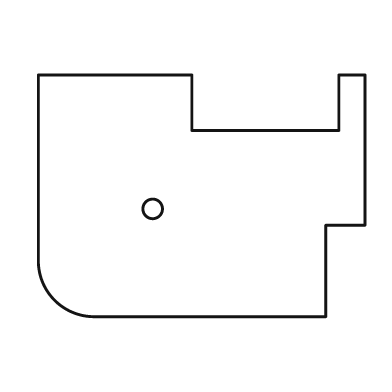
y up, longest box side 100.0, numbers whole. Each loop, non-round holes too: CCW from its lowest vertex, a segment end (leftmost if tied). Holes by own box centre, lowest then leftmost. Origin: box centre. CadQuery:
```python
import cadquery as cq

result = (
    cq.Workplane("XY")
    .moveTo(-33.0, -37.0)
    .lineTo(38.0, -37.0)
    .lineTo(38.0, -9.0)
    .lineTo(50.0, -9.0)
    .lineTo(50.0, 37.0)
    .lineTo(42.0, 37.0)
    .lineTo(42.0, 20.0)
    .lineTo(-3.0, 20.0)
    .lineTo(-3.0, 37.0)
    .lineTo(-50.0, 37.0)
    .lineTo(-50.0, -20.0)
    .threePointArc((-45.0, -32.0), (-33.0, -37.0))
    .close()
    .moveTo(-15.0, -4.0)
    .circle(3.0)
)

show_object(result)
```